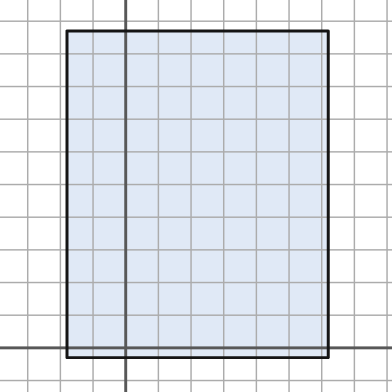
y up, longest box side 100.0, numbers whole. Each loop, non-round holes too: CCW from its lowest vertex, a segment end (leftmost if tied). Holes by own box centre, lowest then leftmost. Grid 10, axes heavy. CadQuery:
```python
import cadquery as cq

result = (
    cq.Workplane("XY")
    .moveTo(-18.0, -3.0)
    .lineTo(62.0, -3.0)
    .lineTo(62.0, 97.0)
    .lineTo(-18.0, 97.0)
    .close()
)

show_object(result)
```